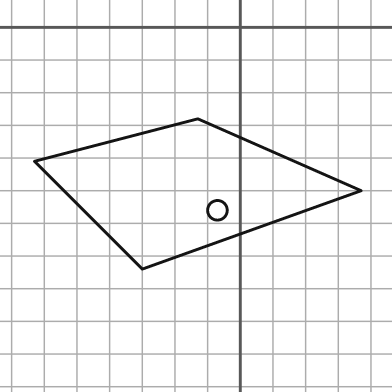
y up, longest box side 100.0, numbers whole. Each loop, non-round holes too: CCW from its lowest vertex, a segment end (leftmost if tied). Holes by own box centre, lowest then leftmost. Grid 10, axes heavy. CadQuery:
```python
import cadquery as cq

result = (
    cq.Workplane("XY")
    .moveTo(-30.0, -74.0)
    .lineTo(37.0, -50.0)
    .lineTo(-13.0, -28.0)
    .lineTo(-63.0, -41.0)
    .close()
    .moveTo(-7.0, -56.0)
    .circle(3.0)
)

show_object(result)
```